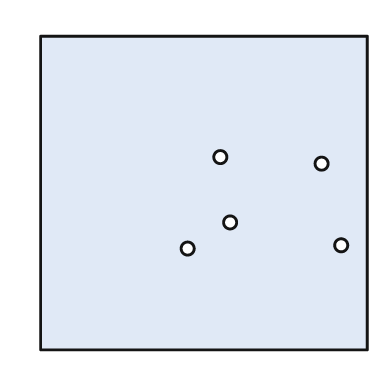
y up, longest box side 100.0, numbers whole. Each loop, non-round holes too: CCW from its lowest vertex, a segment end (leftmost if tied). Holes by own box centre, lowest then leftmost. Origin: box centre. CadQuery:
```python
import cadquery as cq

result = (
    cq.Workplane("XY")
    .moveTo(-50.0, -48.0)
    .lineTo(50.0, -48.0)
    .lineTo(50.0, 48.0)
    .lineTo(-50.0, 48.0)
    .close()
    .moveTo(-5.0, -17.0)
    .circle(2.0)
    .moveTo(42.0, -16.0)
    .circle(2.0)
    .moveTo(8.0, -9.0)
    .circle(2.0)
    .moveTo(36.0, 9.0)
    .circle(2.0)
    .moveTo(5.0, 11.0)
    .circle(2.0)
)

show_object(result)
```